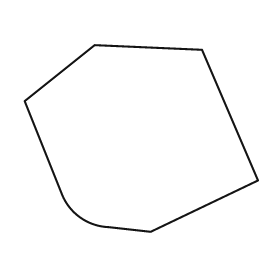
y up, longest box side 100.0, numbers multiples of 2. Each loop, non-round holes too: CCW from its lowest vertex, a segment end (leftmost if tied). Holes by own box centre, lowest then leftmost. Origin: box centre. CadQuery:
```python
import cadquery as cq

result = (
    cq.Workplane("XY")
    .moveTo(4.0, -40.0)
    .lineTo(50.0, -18.0)
    .lineTo(26.0, 38.0)
    .lineTo(-20.0, 40.0)
    .lineTo(-50.0, 16.0)
    .lineTo(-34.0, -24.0)
    .threePointArc((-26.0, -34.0), (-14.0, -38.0))
    .close()
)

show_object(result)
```